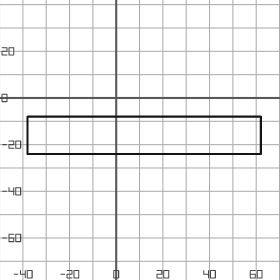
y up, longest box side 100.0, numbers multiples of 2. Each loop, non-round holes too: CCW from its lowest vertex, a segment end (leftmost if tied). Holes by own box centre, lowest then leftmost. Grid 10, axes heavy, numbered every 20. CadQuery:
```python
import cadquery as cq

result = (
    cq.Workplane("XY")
    .moveTo(-38.0, -24.0)
    .lineTo(62.0, -24.0)
    .lineTo(62.0, -8.0)
    .lineTo(-38.0, -8.0)
    .close()
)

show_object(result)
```